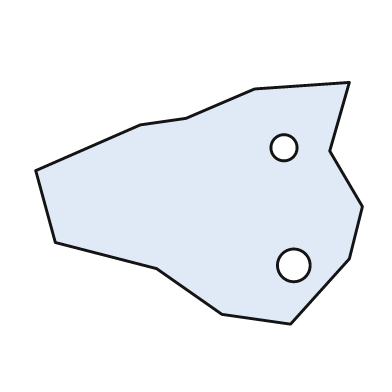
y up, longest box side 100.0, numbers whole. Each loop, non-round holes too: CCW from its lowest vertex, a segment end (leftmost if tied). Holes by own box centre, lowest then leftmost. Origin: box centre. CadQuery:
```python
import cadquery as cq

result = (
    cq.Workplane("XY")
    .moveTo(28.0, -37.0)
    .lineTo(46.0, -17.0)
    .lineTo(50.0, -1.0)
    .lineTo(40.0, 16.0)
    .lineTo(46.0, 37.0)
    .lineTo(17.0, 35.0)
    .lineTo(-4.0, 26.0)
    .lineTo(-18.0, 24.0)
    .lineTo(-50.0, 10.0)
    .lineTo(-44.0, -12.0)
    .lineTo(-13.0, -20.0)
    .lineTo(7.0, -34.0)
    .close()
    .moveTo(29.0, -19.0)
    .circle(5.0)
    .moveTo(26.0, 17.0)
    .circle(4.0)
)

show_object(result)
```